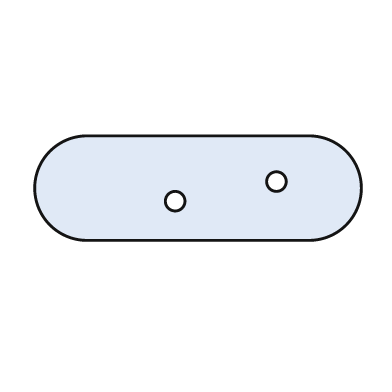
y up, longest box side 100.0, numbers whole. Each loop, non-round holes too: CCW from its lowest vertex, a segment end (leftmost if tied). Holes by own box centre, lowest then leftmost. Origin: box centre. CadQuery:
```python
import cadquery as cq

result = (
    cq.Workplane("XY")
    .moveTo(-34.0, -16.0)
    .lineTo(34.0, -16.0)
    .threePointArc((50.0, 0.0), (34.0, 16.0))
    .lineTo(-34.0, 16.0)
    .threePointArc((-50.0, 0.0), (-34.0, -16.0))
    .close()
    .moveTo(-7.0, -4.0)
    .circle(3.0)
    .moveTo(24.0, 2.0)
    .circle(3.0)
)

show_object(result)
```